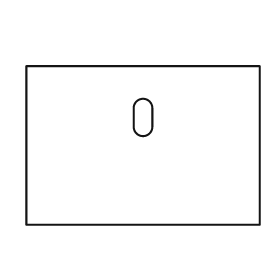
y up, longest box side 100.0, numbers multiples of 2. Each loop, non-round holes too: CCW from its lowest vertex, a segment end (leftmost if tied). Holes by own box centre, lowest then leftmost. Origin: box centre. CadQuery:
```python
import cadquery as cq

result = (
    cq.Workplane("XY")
    .moveTo(-50.0, -34.0)
    .lineTo(50.0, -34.0)
    .lineTo(50.0, 34.0)
    .lineTo(-50.0, 34.0)
    .close()
    .moveTo(-4.0, 8.0)
    .threePointArc((0.0, 4.0), (4.0, 8.0))
    .lineTo(4.0, 16.0)
    .threePointArc((0.0, 20.0), (-4.0, 16.0))
    .close()
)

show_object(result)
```